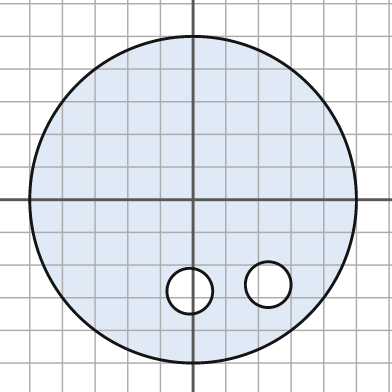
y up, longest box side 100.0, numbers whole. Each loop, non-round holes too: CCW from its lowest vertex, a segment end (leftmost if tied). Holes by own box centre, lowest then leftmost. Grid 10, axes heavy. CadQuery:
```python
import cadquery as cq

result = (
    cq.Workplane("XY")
    .moveTo(0.0, 0.0)
    .circle(50.0)
    .moveTo(-1.0, -28.0)
    .circle(7.0)
    .moveTo(23.0, -26.0)
    .circle(7.0)
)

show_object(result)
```